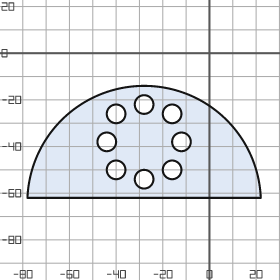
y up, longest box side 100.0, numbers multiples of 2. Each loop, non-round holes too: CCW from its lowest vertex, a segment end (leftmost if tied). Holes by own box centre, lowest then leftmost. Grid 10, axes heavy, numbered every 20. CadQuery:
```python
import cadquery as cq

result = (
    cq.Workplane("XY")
    .moveTo(-78.0, -62.0)
    .lineTo(22.0, -62.0)
    .threePointArc((-28.0, -14.0), (-78.0, -62.0))
    .close()
    .moveTo(-28.0, -54.0)
    .circle(4.0)
    .moveTo(-40.0, -50.0)
    .circle(4.0)
    .moveTo(-16.0, -50.0)
    .circle(4.0)
    .moveTo(-44.0, -38.0)
    .circle(4.0)
    .moveTo(-12.0, -38.0)
    .circle(4.0)
    .moveTo(-40.0, -26.0)
    .circle(4.0)
    .moveTo(-16.0, -26.0)
    .circle(4.0)
    .moveTo(-28.0, -22.0)
    .circle(4.0)
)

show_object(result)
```